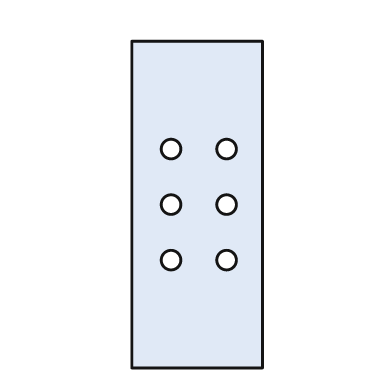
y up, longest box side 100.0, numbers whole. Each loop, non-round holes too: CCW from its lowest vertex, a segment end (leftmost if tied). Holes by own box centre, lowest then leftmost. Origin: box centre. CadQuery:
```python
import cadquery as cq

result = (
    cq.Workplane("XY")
    .moveTo(-20.0, -50.0)
    .lineTo(20.0, -50.0)
    .lineTo(20.0, 50.0)
    .lineTo(-20.0, 50.0)
    .close()
    .moveTo(-8.0, -17.0)
    .circle(3.0)
    .moveTo(9.0, -17.0)
    .circle(3.0)
    .moveTo(-8.0, 0.0)
    .circle(3.0)
    .moveTo(9.0, 0.0)
    .circle(3.0)
    .moveTo(-8.0, 17.0)
    .circle(3.0)
    .moveTo(9.0, 17.0)
    .circle(3.0)
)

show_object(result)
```